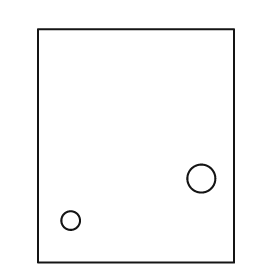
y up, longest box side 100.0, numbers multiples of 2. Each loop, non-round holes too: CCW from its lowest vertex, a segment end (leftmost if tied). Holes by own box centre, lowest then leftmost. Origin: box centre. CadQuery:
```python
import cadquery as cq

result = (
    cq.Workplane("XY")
    .moveTo(-42.0, -50.0)
    .lineTo(42.0, -50.0)
    .lineTo(42.0, 50.0)
    .lineTo(-42.0, 50.0)
    .close()
    .moveTo(-28.0, -32.0)
    .circle(4.0)
    .moveTo(28.0, -14.0)
    .circle(6.0)
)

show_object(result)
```